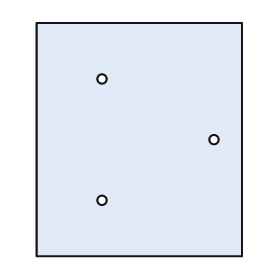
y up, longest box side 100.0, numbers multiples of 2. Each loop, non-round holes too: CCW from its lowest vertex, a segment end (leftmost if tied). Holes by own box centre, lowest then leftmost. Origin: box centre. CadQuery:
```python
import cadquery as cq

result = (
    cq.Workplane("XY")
    .moveTo(-44.0, -50.0)
    .lineTo(44.0, -50.0)
    .lineTo(44.0, 50.0)
    .lineTo(-44.0, 50.0)
    .close()
    .moveTo(-16.0, -26.0)
    .circle(2.0)
    .moveTo(32.0, 0.0)
    .circle(2.0)
    .moveTo(-16.0, 26.0)
    .circle(2.0)
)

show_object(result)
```